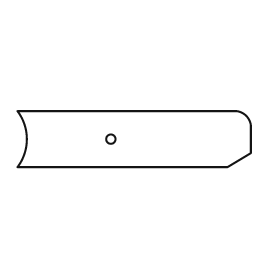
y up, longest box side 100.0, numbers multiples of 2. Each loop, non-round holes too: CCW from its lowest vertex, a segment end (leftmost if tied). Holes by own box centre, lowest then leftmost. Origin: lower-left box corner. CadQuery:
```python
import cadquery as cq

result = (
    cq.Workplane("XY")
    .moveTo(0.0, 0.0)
    .lineTo(90.0, 0.0)
    .lineTo(100.0, 6.0)
    .lineTo(100.0, 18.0)
    .threePointArc((98.0, 22.0), (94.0, 24.0))
    .lineTo(0.0, 24.0)
    .threePointArc((4.0, 12.0), (0.0, 0.0))
    .close()
    .moveTo(40.0, 12.0)
    .circle(2.0)
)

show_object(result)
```